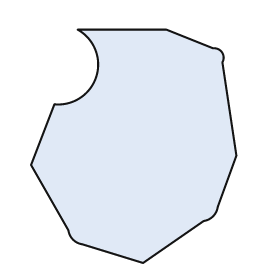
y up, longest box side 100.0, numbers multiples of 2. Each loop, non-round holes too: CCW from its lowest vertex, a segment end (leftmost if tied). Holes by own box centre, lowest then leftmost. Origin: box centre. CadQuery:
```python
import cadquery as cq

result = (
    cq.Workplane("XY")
    .moveTo(4.0, -50.0)
    .lineTo(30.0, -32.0)
    .threePointArc((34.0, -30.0), (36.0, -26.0))
    .lineTo(44.0, -4.0)
    .lineTo(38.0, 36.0)
    .threePointArc((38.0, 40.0), (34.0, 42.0))
    .lineTo(14.0, 50.0)
    .lineTo(-24.0, 50.0)
    .threePointArc((-16.0, 30.0), (-34.0, 18.0))
    .lineTo(-44.0, -8.0)
    .lineTo(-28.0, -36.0)
    .threePointArc((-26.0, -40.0), (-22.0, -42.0))
    .close()
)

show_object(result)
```